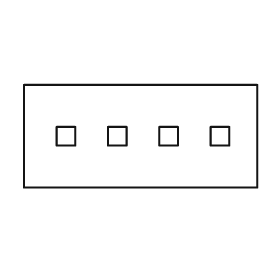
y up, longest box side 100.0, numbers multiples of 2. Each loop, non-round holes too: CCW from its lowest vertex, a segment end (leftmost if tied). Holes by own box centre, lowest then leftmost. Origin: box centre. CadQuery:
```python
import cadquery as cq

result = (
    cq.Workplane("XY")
    .moveTo(-50.0, -22.0)
    .lineTo(50.0, -22.0)
    .lineTo(50.0, 22.0)
    .lineTo(-50.0, 22.0)
    .close()
    .moveTo(-36.0, -4.0)
    .lineTo(-28.0, -4.0)
    .lineTo(-28.0, 4.0)
    .lineTo(-36.0, 4.0)
    .close()
    .moveTo(-14.0, -4.0)
    .lineTo(-6.0, -4.0)
    .lineTo(-6.0, 4.0)
    .lineTo(-14.0, 4.0)
    .close()
    .moveTo(8.0, -4.0)
    .lineTo(16.0, -4.0)
    .lineTo(16.0, 4.0)
    .lineTo(8.0, 4.0)
    .close()
    .moveTo(30.0, -4.0)
    .lineTo(38.0, -4.0)
    .lineTo(38.0, 4.0)
    .lineTo(30.0, 4.0)
    .close()
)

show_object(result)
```